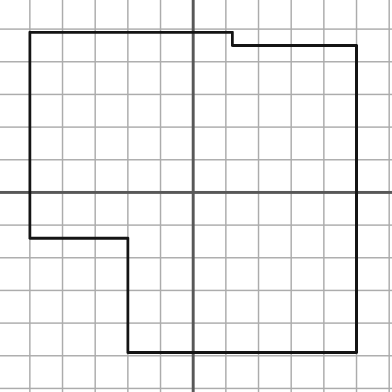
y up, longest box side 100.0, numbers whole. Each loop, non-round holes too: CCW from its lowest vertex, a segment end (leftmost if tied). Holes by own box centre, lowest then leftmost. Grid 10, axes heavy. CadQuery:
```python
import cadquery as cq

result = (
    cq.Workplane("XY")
    .moveTo(-20.0, -49.0)
    .lineTo(50.0, -49.0)
    .lineTo(50.0, 45.0)
    .lineTo(12.0, 45.0)
    .lineTo(12.0, 49.0)
    .lineTo(-50.0, 49.0)
    .lineTo(-50.0, -14.0)
    .lineTo(-20.0, -14.0)
    .close()
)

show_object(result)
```